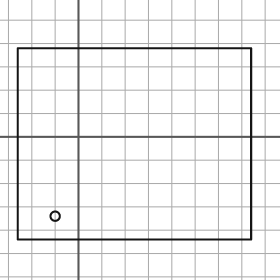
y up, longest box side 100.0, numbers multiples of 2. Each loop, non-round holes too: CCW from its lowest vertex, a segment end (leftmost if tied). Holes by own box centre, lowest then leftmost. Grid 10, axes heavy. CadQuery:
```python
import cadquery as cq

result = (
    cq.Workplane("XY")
    .moveTo(-26.0, -44.0)
    .lineTo(74.0, -44.0)
    .lineTo(74.0, 38.0)
    .lineTo(-26.0, 38.0)
    .close()
    .moveTo(-10.0, -34.0)
    .circle(2.0)
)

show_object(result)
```